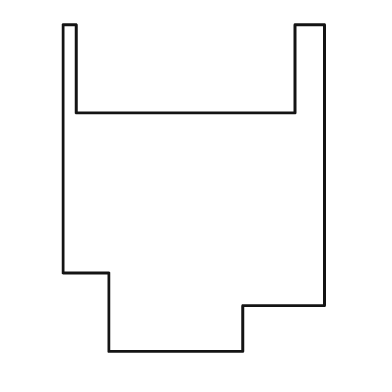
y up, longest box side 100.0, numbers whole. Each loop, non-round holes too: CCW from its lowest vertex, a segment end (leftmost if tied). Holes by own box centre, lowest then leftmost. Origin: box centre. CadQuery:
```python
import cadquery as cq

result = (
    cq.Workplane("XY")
    .moveTo(-26.0, -50.0)
    .lineTo(15.0, -50.0)
    .lineTo(15.0, -36.0)
    .lineTo(40.0, -36.0)
    .lineTo(40.0, 50.0)
    .lineTo(31.0, 50.0)
    .lineTo(31.0, 23.0)
    .lineTo(-36.0, 23.0)
    .lineTo(-36.0, 50.0)
    .lineTo(-40.0, 50.0)
    .lineTo(-40.0, -26.0)
    .lineTo(-26.0, -26.0)
    .close()
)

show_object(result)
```